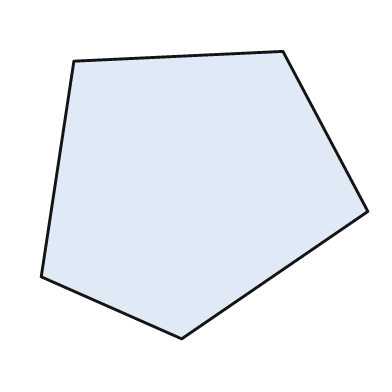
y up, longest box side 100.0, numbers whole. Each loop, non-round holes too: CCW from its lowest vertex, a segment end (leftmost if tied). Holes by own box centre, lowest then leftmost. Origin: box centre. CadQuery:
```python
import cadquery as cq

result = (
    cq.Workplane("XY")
    .moveTo(-7.0, -44.0)
    .lineTo(50.0, -5.0)
    .lineTo(24.0, 44.0)
    .lineTo(-40.0, 41.0)
    .lineTo(-50.0, -25.0)
    .close()
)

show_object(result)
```